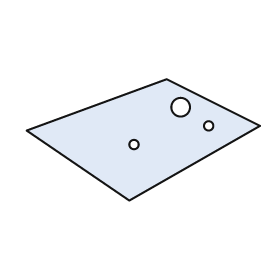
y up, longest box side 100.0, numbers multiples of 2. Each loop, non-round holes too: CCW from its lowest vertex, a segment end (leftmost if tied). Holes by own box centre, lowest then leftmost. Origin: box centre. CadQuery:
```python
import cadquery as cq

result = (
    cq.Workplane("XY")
    .moveTo(-6.0, -26.0)
    .lineTo(50.0, 6.0)
    .lineTo(10.0, 26.0)
    .lineTo(-50.0, 4.0)
    .close()
    .moveTo(-4.0, -2.0)
    .circle(2.0)
    .moveTo(28.0, 6.0)
    .circle(2.0)
    .moveTo(16.0, 14.0)
    .circle(4.0)
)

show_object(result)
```